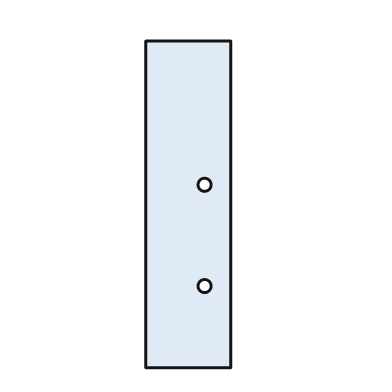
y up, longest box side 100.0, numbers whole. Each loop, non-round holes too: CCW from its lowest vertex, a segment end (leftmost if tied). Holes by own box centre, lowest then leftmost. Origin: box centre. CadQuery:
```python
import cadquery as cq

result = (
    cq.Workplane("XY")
    .moveTo(-13.0, -50.0)
    .lineTo(13.0, -50.0)
    .lineTo(13.0, 50.0)
    .lineTo(-13.0, 50.0)
    .close()
    .moveTo(5.0, -25.0)
    .circle(2.0)
    .moveTo(5.0, 6.0)
    .circle(2.0)
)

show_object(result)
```